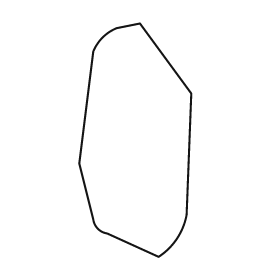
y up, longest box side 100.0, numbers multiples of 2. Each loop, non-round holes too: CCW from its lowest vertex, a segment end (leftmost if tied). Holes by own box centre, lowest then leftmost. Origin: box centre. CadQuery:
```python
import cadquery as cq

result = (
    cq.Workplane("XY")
    .moveTo(10.0, -50.0)
    .threePointArc((18.0, -42.0), (22.0, -32.0))
    .lineTo(24.0, 20.0)
    .lineTo(2.0, 50.0)
    .lineTo(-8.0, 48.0)
    .threePointArc((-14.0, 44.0), (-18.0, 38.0))
    .lineTo(-24.0, -10.0)
    .lineTo(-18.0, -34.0)
    .threePointArc((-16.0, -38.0), (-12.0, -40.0))
    .close()
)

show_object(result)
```